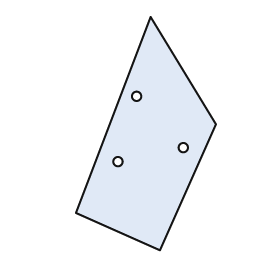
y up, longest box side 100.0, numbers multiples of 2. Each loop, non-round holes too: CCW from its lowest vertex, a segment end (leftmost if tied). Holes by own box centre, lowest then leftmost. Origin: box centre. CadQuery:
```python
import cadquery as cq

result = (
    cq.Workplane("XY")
    .moveTo(6.0, -50.0)
    .lineTo(30.0, 4.0)
    .lineTo(2.0, 50.0)
    .lineTo(-30.0, -34.0)
    .close()
    .moveTo(-12.0, -12.0)
    .circle(2.0)
    .moveTo(16.0, -6.0)
    .circle(2.0)
    .moveTo(-4.0, 16.0)
    .circle(2.0)
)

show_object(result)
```